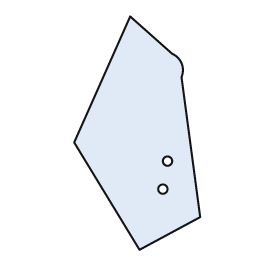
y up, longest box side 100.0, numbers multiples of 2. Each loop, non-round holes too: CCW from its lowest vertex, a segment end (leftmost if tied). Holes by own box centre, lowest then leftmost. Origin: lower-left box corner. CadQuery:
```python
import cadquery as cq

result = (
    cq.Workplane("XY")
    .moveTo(28.0, 0.0)
    .lineTo(54.0, 14.0)
    .lineTo(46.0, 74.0)
    .threePointArc((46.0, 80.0), (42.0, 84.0))
    .lineTo(24.0, 100.0)
    .lineTo(0.0, 46.0)
    .close()
    .moveTo(38.0, 26.0)
    .circle(2.0)
    .moveTo(40.0, 38.0)
    .circle(2.0)
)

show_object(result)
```